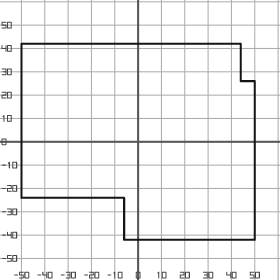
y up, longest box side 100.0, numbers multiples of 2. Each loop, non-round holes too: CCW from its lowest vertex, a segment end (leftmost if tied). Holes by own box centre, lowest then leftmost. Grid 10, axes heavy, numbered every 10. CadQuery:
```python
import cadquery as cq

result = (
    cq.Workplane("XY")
    .moveTo(-6.0, -42.0)
    .lineTo(50.0, -42.0)
    .lineTo(50.0, 26.0)
    .lineTo(44.0, 26.0)
    .lineTo(44.0, 42.0)
    .lineTo(-50.0, 42.0)
    .lineTo(-50.0, -24.0)
    .lineTo(-6.0, -24.0)
    .close()
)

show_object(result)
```